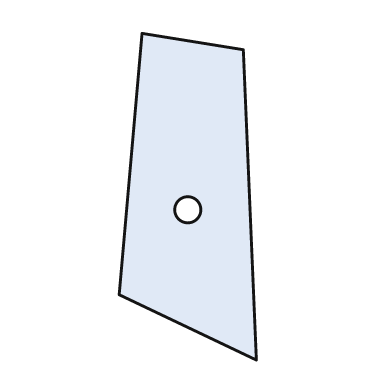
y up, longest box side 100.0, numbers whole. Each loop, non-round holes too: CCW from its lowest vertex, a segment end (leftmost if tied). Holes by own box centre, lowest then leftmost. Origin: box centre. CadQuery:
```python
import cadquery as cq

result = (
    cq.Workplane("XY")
    .moveTo(21.0, -50.0)
    .lineTo(17.0, 45.0)
    .lineTo(-14.0, 50.0)
    .lineTo(-21.0, -30.0)
    .close()
    .moveTo(0.0, -4.0)
    .circle(4.0)
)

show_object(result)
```